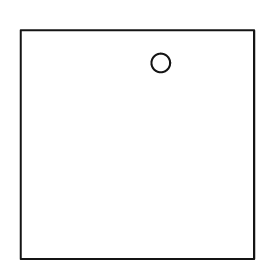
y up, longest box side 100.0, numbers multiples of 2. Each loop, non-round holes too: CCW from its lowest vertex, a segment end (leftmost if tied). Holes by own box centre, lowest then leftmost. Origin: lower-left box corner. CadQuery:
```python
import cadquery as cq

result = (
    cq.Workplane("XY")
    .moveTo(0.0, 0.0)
    .lineTo(100.0, 0.0)
    .lineTo(100.0, 98.0)
    .lineTo(0.0, 98.0)
    .close()
    .moveTo(60.0, 84.0)
    .circle(4.0)
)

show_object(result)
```